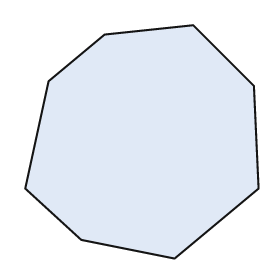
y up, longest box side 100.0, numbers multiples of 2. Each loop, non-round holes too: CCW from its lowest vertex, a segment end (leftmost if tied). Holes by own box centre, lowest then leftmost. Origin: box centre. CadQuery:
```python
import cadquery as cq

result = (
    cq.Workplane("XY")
    .moveTo(14.0, -50.0)
    .lineTo(50.0, -20.0)
    .lineTo(48.0, 24.0)
    .lineTo(22.0, 50.0)
    .lineTo(-16.0, 46.0)
    .lineTo(-40.0, 26.0)
    .lineTo(-50.0, -20.0)
    .lineTo(-26.0, -42.0)
    .close()
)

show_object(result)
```